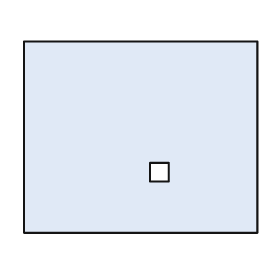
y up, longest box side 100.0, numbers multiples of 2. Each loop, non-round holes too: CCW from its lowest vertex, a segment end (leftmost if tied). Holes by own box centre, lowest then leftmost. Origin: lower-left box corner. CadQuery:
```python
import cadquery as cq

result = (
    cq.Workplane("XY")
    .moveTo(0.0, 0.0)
    .lineTo(100.0, 0.0)
    .lineTo(100.0, 82.0)
    .lineTo(0.0, 82.0)
    .close()
    .moveTo(54.0, 22.0)
    .lineTo(62.0, 22.0)
    .lineTo(62.0, 30.0)
    .lineTo(54.0, 30.0)
    .close()
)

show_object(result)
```